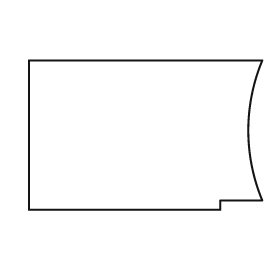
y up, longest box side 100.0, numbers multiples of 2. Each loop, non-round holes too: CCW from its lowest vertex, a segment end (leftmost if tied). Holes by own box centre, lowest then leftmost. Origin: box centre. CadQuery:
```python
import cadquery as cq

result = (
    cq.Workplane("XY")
    .moveTo(-50.0, -32.0)
    .lineTo(32.0, -32.0)
    .lineTo(32.0, -28.0)
    .lineTo(50.0, -28.0)
    .threePointArc((44.0, 2.0), (50.0, 32.0))
    .lineTo(-50.0, 32.0)
    .close()
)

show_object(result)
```